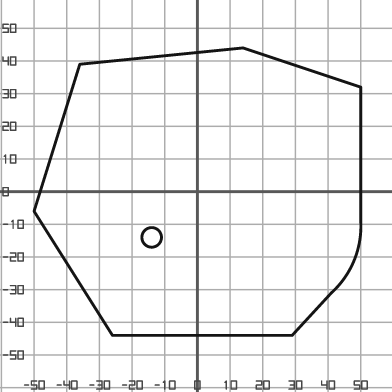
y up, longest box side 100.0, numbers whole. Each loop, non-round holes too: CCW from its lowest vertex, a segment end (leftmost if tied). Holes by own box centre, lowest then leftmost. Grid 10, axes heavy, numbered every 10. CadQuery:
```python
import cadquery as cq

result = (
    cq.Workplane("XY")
    .moveTo(-26.0, -44.0)
    .lineTo(29.0, -44.0)
    .lineTo(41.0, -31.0)
    .threePointArc((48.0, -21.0), (50.0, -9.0))
    .lineTo(50.0, 32.0)
    .lineTo(14.0, 44.0)
    .lineTo(-36.0, 39.0)
    .lineTo(-50.0, -6.0)
    .close()
    .moveTo(-14.0, -14.0)
    .circle(3.0)
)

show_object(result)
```